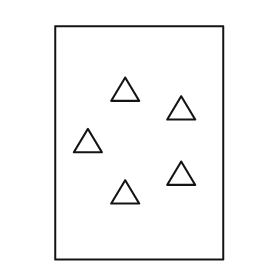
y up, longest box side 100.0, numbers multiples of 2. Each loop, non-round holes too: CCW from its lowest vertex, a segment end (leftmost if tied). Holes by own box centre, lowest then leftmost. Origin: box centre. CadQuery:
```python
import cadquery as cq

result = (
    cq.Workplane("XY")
    .moveTo(-36.0, -50.0)
    .lineTo(36.0, -50.0)
    .lineTo(36.0, 50.0)
    .lineTo(-36.0, 50.0)
    .close()
    .moveTo(-12.0, -26.0)
    .lineTo(0.0, -26.0)
    .lineTo(-6.0, -16.0)
    .close()
    .moveTo(12.0, -18.0)
    .lineTo(24.0, -18.0)
    .lineTo(18.0, -8.0)
    .close()
    .moveTo(-28.0, -4.0)
    .lineTo(-16.0, -4.0)
    .lineTo(-22.0, 6.0)
    .close()
    .moveTo(12.0, 10.0)
    .lineTo(24.0, 10.0)
    .lineTo(18.0, 20.0)
    .close()
    .moveTo(-12.0, 18.0)
    .lineTo(0.0, 18.0)
    .lineTo(-6.0, 28.0)
    .close()
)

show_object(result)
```